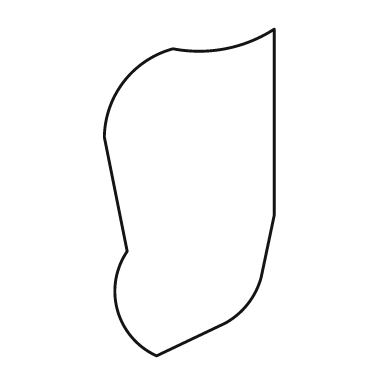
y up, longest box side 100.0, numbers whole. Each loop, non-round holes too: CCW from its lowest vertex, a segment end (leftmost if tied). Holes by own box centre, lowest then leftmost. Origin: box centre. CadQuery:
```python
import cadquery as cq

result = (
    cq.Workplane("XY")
    .moveTo(-10.0, -50.0)
    .lineTo(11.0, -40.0)
    .threePointArc((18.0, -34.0), (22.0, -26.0))
    .lineTo(26.0, -7.0)
    .lineTo(26.0, 50.0)
    .threePointArc((11.0, 44.0), (-5.0, 44.0))
    .threePointArc((-20.0, 34.0), (-26.0, 17.0))
    .lineTo(-19.0, -18.0)
    .threePointArc((-22.0, -36.0), (-10.0, -50.0))
    .close()
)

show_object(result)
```